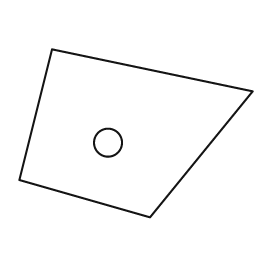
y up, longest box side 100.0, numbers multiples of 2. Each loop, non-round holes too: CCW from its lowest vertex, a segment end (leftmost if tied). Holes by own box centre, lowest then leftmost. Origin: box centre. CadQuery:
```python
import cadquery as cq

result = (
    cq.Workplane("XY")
    .moveTo(6.0, -36.0)
    .lineTo(50.0, 18.0)
    .lineTo(-36.0, 36.0)
    .lineTo(-50.0, -20.0)
    .close()
    .moveTo(-12.0, -4.0)
    .circle(6.0)
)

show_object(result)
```